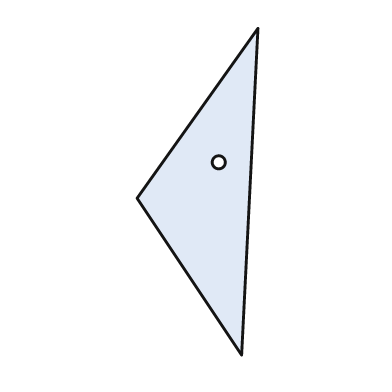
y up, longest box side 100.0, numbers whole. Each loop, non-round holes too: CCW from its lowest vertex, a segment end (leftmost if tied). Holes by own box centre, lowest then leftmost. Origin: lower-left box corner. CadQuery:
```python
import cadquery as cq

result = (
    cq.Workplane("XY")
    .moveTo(32.0, 0.0)
    .lineTo(37.0, 100.0)
    .lineTo(0.0, 48.0)
    .close()
    .moveTo(25.0, 59.0)
    .circle(2.0)
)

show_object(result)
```